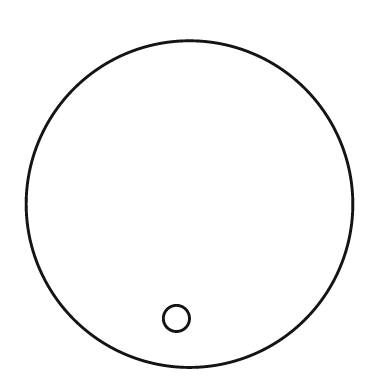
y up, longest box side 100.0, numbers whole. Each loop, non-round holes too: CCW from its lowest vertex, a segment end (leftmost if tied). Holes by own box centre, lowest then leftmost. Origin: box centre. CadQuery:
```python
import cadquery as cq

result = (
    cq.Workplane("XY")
    .moveTo(0.0, 0.0)
    .circle(50.0)
    .moveTo(-4.0, -35.0)
    .circle(4.0)
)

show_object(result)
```